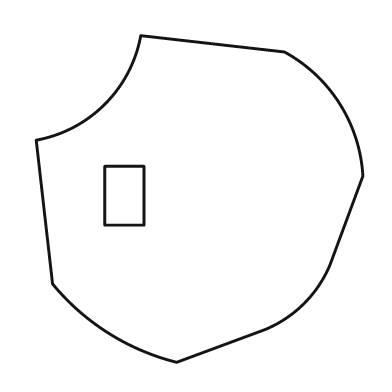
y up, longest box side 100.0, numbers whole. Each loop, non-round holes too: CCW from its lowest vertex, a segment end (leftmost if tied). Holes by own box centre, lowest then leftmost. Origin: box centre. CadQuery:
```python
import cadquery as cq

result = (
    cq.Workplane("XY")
    .moveTo(-7.0, -50.0)
    .lineTo(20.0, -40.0)
    .threePointArc((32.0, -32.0), (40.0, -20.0))
    .lineTo(50.0, 7.0)
    .threePointArc((43.0, 29.0), (26.0, 45.0))
    .lineTo(-18.0, 50.0)
    .threePointArc((-29.0, 29.0), (-50.0, 18.0))
    .lineTo(-45.0, -26.0)
    .threePointArc((-28.0, -41.0), (-7.0, -50.0))
    .close()
    .moveTo(-29.0, -8.0)
    .lineTo(-17.0, -8.0)
    .lineTo(-17.0, 10.0)
    .lineTo(-29.0, 10.0)
    .close()
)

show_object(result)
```